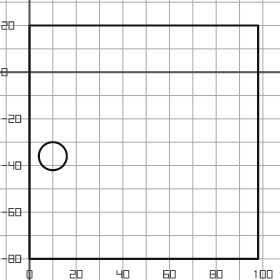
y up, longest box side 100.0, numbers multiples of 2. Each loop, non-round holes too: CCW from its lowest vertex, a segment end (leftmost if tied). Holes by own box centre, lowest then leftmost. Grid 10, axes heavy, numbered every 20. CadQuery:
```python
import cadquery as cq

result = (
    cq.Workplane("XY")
    .moveTo(0.0, -80.0)
    .lineTo(98.0, -80.0)
    .lineTo(98.0, 20.0)
    .lineTo(0.0, 20.0)
    .close()
    .moveTo(10.0, -36.0)
    .circle(6.0)
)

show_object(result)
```